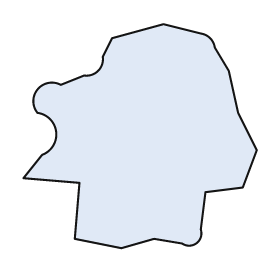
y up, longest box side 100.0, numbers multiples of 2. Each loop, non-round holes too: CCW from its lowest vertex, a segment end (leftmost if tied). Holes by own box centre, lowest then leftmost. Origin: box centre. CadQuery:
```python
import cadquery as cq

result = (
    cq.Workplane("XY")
    .moveTo(-8.0, -48.0)
    .lineTo(6.0, -44.0)
    .lineTo(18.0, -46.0)
    .threePointArc((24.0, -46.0), (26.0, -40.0))
    .lineTo(28.0, -24.0)
    .lineTo(44.0, -22.0)
    .lineTo(50.0, -6.0)
    .lineTo(42.0, 10.0)
    .lineTo(38.0, 28.0)
    .lineTo(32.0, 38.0)
    .threePointArc((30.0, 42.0), (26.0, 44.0))
    .lineTo(10.0, 48.0)
    .lineTo(-12.0, 42.0)
    .lineTo(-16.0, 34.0)
    .threePointArc((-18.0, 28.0), (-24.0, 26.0))
    .lineTo(-34.0, 22.0)
    .threePointArc((-44.0, 20.0), (-44.0, 10.0))
    .threePointArc((-36.0, 2.0), (-42.0, -8.0))
    .lineTo(-50.0, -18.0)
    .lineTo(-26.0, -20.0)
    .lineTo(-28.0, -44.0)
    .close()
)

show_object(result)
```